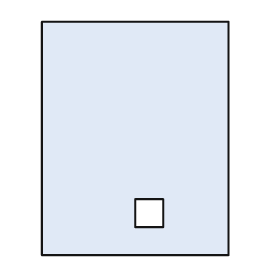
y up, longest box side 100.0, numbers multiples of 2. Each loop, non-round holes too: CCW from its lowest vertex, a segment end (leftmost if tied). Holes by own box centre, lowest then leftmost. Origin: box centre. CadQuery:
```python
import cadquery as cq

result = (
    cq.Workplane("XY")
    .moveTo(-40.0, -50.0)
    .lineTo(40.0, -50.0)
    .lineTo(40.0, 50.0)
    .lineTo(-40.0, 50.0)
    .close()
    .moveTo(0.0, -38.0)
    .lineTo(12.0, -38.0)
    .lineTo(12.0, -26.0)
    .lineTo(0.0, -26.0)
    .close()
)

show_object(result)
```